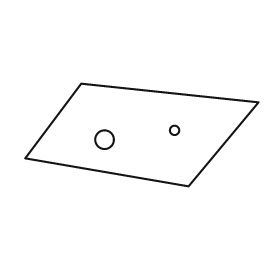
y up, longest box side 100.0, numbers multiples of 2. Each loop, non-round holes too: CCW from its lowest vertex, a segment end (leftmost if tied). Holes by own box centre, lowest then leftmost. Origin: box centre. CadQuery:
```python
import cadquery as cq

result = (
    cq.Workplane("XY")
    .moveTo(20.0, -22.0)
    .lineTo(50.0, 14.0)
    .lineTo(-26.0, 22.0)
    .lineTo(-50.0, -10.0)
    .close()
    .moveTo(-16.0, -2.0)
    .circle(4.0)
    .moveTo(14.0, 2.0)
    .circle(2.0)
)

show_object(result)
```